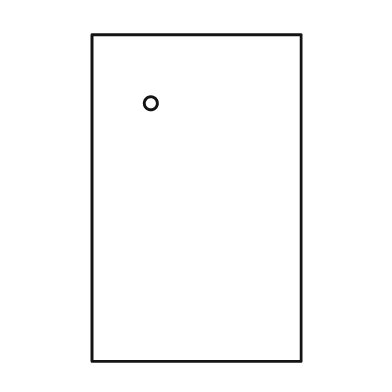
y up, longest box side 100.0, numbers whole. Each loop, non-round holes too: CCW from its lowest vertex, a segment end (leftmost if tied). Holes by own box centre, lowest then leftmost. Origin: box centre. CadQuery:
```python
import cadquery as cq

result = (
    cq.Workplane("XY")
    .moveTo(-32.0, -50.0)
    .lineTo(32.0, -50.0)
    .lineTo(32.0, 50.0)
    .lineTo(-32.0, 50.0)
    .close()
    .moveTo(-14.0, 29.0)
    .circle(2.0)
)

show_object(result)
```